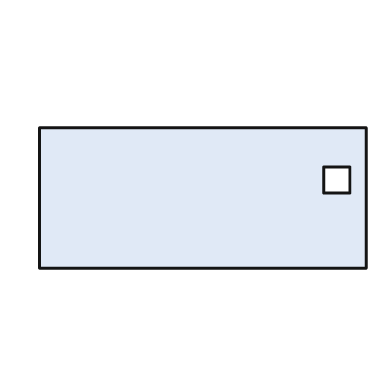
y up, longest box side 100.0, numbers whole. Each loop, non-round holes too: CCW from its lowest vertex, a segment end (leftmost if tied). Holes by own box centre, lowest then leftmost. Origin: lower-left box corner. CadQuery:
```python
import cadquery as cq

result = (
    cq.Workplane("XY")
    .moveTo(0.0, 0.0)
    .lineTo(100.0, 0.0)
    .lineTo(100.0, 43.0)
    .lineTo(0.0, 43.0)
    .close()
    .moveTo(87.0, 23.0)
    .lineTo(95.0, 23.0)
    .lineTo(95.0, 31.0)
    .lineTo(87.0, 31.0)
    .close()
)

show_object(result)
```